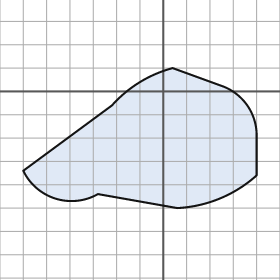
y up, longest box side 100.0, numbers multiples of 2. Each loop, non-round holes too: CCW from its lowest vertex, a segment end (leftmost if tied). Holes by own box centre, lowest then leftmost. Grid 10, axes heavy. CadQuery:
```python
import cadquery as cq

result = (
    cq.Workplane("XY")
    .moveTo(6.0, -50.0)
    .threePointArc((24.0, -46.0), (40.0, -36.0))
    .lineTo(40.0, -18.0)
    .threePointArc((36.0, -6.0), (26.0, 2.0))
    .lineTo(4.0, 10.0)
    .threePointArc((-10.0, 4.0), (-22.0, -6.0))
    .lineTo(-60.0, -34.0)
    .threePointArc((-46.0, -46.0), (-28.0, -44.0))
    .close()
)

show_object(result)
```